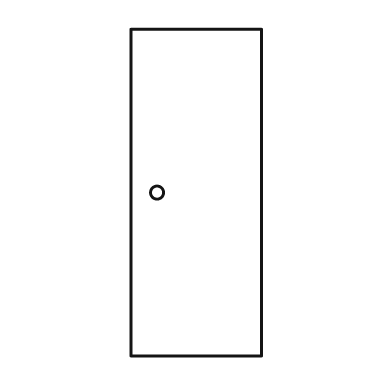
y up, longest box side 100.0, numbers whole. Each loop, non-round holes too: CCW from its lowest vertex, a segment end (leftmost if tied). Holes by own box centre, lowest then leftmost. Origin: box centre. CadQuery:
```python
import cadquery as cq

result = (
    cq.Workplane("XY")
    .moveTo(-20.0, -50.0)
    .lineTo(20.0, -50.0)
    .lineTo(20.0, 50.0)
    .lineTo(-20.0, 50.0)
    .close()
    .moveTo(-12.0, 0.0)
    .circle(2.0)
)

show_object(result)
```